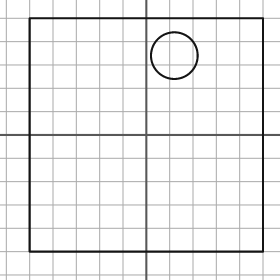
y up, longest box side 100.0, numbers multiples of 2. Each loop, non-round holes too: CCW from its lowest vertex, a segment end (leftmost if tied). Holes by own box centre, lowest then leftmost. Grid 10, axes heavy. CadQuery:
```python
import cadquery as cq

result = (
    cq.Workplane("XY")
    .moveTo(-50.0, -50.0)
    .lineTo(50.0, -50.0)
    .lineTo(50.0, 50.0)
    .lineTo(-50.0, 50.0)
    .close()
    .moveTo(12.0, 34.0)
    .circle(10.0)
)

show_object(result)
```